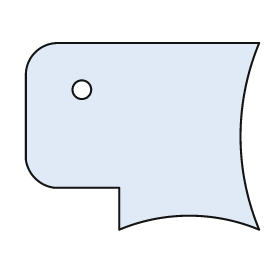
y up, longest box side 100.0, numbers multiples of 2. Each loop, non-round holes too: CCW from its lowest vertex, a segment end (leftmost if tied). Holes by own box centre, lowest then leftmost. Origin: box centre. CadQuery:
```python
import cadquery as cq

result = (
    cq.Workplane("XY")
    .moveTo(-10.0, -40.0)
    .threePointArc((20.0, -34.0), (50.0, -40.0))
    .threePointArc((42.0, 0.0), (50.0, 40.0))
    .lineTo(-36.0, 40.0)
    .threePointArc((-46.0, 36.0), (-50.0, 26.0))
    .lineTo(-50.0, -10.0)
    .threePointArc((-46.0, -18.0), (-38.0, -22.0))
    .lineTo(-10.0, -22.0)
    .close()
    .moveTo(-26.0, 20.0)
    .circle(4.0)
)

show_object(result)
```